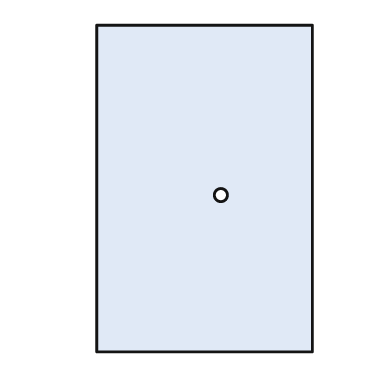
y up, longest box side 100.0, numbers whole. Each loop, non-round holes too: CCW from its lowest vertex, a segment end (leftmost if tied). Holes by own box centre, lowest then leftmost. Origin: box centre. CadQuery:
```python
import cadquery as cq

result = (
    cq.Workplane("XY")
    .moveTo(-33.0, -50.0)
    .lineTo(33.0, -50.0)
    .lineTo(33.0, 50.0)
    .lineTo(-33.0, 50.0)
    .close()
    .moveTo(5.0, -2.0)
    .circle(2.0)
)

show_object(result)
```